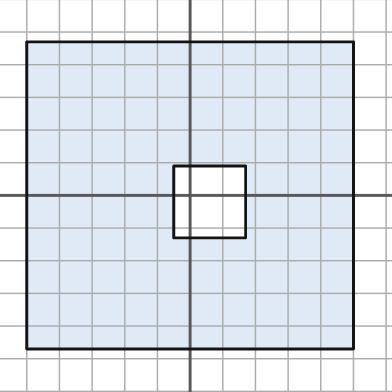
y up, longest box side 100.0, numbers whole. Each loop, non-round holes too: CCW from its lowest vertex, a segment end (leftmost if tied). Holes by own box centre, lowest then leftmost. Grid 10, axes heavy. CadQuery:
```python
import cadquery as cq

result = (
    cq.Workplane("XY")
    .moveTo(-50.0, -47.0)
    .lineTo(50.0, -47.0)
    .lineTo(50.0, 47.0)
    .lineTo(-50.0, 47.0)
    .close()
    .moveTo(-5.0, -13.0)
    .lineTo(17.0, -13.0)
    .lineTo(17.0, 9.0)
    .lineTo(-5.0, 9.0)
    .close()
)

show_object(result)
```